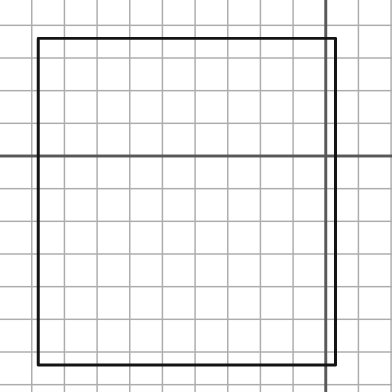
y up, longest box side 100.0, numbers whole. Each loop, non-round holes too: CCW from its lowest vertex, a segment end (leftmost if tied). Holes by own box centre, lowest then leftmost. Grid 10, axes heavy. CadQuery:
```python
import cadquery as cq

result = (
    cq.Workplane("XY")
    .moveTo(-88.0, -64.0)
    .lineTo(3.0, -64.0)
    .lineTo(3.0, 36.0)
    .lineTo(-88.0, 36.0)
    .close()
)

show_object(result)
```